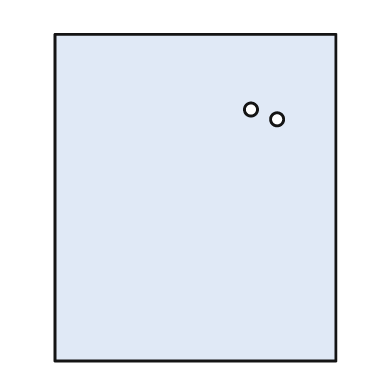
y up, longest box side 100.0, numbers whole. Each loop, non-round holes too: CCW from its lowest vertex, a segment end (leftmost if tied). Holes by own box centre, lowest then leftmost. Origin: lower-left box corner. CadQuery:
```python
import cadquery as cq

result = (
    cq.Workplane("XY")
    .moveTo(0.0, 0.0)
    .lineTo(86.0, 0.0)
    .lineTo(86.0, 100.0)
    .lineTo(0.0, 100.0)
    .close()
    .moveTo(68.0, 74.0)
    .circle(2.0)
    .moveTo(60.0, 77.0)
    .circle(2.0)
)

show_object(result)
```